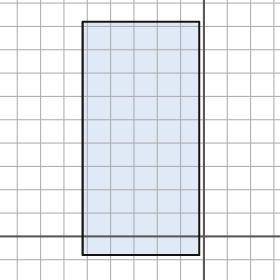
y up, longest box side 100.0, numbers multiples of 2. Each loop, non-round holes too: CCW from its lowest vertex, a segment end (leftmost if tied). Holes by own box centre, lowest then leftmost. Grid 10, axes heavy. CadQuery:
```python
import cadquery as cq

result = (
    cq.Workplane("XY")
    .moveTo(-52.0, -8.0)
    .lineTo(-2.0, -8.0)
    .lineTo(-2.0, 92.0)
    .lineTo(-52.0, 92.0)
    .close()
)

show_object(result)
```